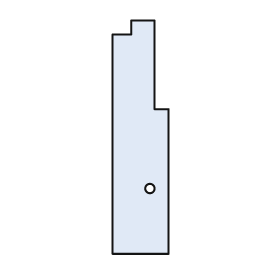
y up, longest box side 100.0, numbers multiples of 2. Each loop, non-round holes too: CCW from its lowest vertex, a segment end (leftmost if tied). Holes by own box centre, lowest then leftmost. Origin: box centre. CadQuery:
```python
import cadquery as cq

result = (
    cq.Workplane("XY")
    .moveTo(-12.0, -50.0)
    .lineTo(12.0, -50.0)
    .lineTo(12.0, 12.0)
    .lineTo(6.0, 12.0)
    .lineTo(6.0, 50.0)
    .lineTo(-4.0, 50.0)
    .lineTo(-4.0, 44.0)
    .lineTo(-12.0, 44.0)
    .close()
    .moveTo(4.0, -22.0)
    .circle(2.0)
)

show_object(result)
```